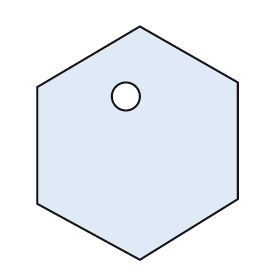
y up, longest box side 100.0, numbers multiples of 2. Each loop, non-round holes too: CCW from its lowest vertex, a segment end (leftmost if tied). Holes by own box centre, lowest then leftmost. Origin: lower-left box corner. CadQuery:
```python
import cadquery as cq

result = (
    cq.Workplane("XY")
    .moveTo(44.0, 0.0)
    .lineTo(86.0, 26.0)
    .lineTo(86.0, 76.0)
    .lineTo(44.0, 100.0)
    .lineTo(0.0, 74.0)
    .lineTo(0.0, 24.0)
    .close()
    .moveTo(38.0, 70.0)
    .circle(6.0)
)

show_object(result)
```